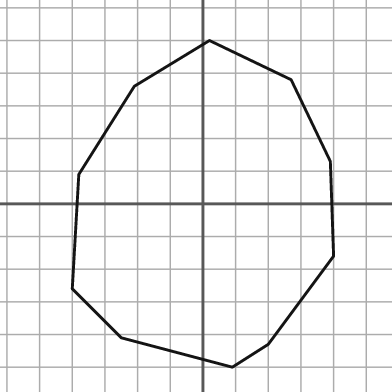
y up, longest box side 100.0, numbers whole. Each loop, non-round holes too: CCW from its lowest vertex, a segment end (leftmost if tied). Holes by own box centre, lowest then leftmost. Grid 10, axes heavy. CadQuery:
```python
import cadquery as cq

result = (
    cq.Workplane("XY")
    .moveTo(9.0, -50.0)
    .lineTo(20.0, -43.0)
    .lineTo(40.0, -16.0)
    .lineTo(39.0, 13.0)
    .lineTo(27.0, 38.0)
    .lineTo(2.0, 50.0)
    .lineTo(-21.0, 36.0)
    .lineTo(-38.0, 9.0)
    .lineTo(-40.0, -26.0)
    .lineTo(-25.0, -41.0)
    .close()
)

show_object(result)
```